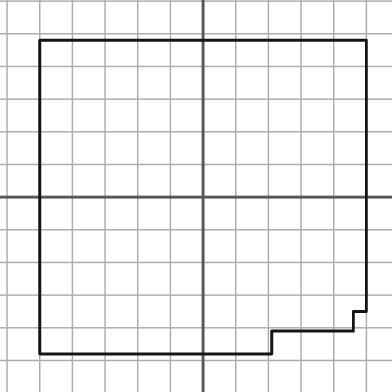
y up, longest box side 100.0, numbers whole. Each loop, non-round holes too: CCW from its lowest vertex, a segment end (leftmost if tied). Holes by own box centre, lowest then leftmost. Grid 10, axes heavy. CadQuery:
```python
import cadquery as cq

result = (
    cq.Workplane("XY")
    .moveTo(-50.0, -48.0)
    .lineTo(21.0, -48.0)
    .lineTo(21.0, -41.0)
    .lineTo(46.0, -41.0)
    .lineTo(46.0, -35.0)
    .lineTo(50.0, -35.0)
    .lineTo(50.0, 48.0)
    .lineTo(-50.0, 48.0)
    .close()
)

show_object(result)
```